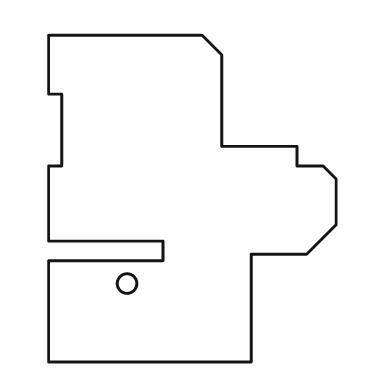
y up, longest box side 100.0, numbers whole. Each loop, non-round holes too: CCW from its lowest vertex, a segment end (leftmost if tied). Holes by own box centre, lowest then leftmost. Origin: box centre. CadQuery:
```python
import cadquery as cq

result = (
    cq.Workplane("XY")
    .moveTo(-44.0, -50.0)
    .lineTo(18.0, -50.0)
    .lineTo(18.0, -17.0)
    .lineTo(35.0, -17.0)
    .lineTo(44.0, -8.0)
    .lineTo(44.0, 6.0)
    .lineTo(40.0, 10.0)
    .lineTo(32.0, 10.0)
    .lineTo(32.0, 16.0)
    .lineTo(9.0, 16.0)
    .lineTo(9.0, 44.0)
    .lineTo(3.0, 50.0)
    .lineTo(-44.0, 50.0)
    .lineTo(-44.0, 32.0)
    .lineTo(-40.0, 32.0)
    .lineTo(-40.0, 10.0)
    .lineTo(-44.0, 10.0)
    .lineTo(-44.0, -13.0)
    .lineTo(-9.0, -13.0)
    .lineTo(-9.0, -19.0)
    .lineTo(-44.0, -19.0)
    .close()
    .moveTo(-20.0, -26.0)
    .circle(3.0)
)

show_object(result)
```